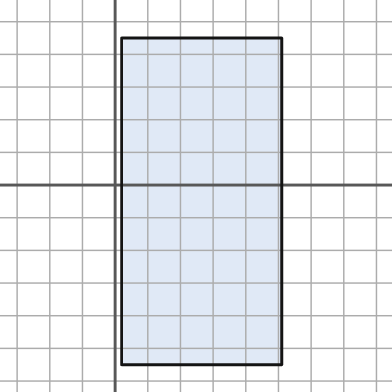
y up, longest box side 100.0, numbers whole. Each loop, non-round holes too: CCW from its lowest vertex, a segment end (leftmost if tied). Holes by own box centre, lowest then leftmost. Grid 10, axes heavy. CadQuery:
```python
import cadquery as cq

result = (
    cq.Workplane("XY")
    .moveTo(2.0, -55.0)
    .lineTo(51.0, -55.0)
    .lineTo(51.0, 45.0)
    .lineTo(2.0, 45.0)
    .close()
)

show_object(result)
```